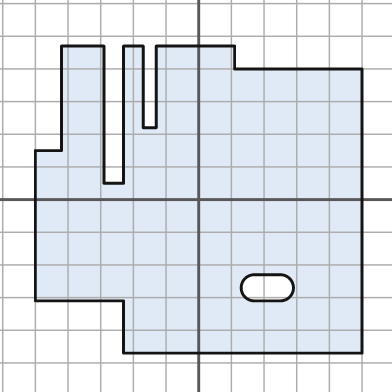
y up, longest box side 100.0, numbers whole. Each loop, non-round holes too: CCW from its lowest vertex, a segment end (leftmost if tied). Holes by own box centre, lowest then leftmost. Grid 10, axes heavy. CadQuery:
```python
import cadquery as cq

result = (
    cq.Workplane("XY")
    .moveTo(-23.0, -47.0)
    .lineTo(50.0, -47.0)
    .lineTo(50.0, 40.0)
    .lineTo(11.0, 40.0)
    .lineTo(11.0, 47.0)
    .lineTo(-13.0, 47.0)
    .lineTo(-13.0, 22.0)
    .lineTo(-17.0, 22.0)
    .lineTo(-17.0, 47.0)
    .lineTo(-23.0, 47.0)
    .lineTo(-23.0, 5.0)
    .lineTo(-29.0, 5.0)
    .lineTo(-29.0, 47.0)
    .lineTo(-42.0, 47.0)
    .lineTo(-42.0, 15.0)
    .lineTo(-50.0, 15.0)
    .lineTo(-50.0, -31.0)
    .lineTo(-23.0, -31.0)
    .close()
    .moveTo(17.0, -31.0)
    .lineTo(25.0, -31.0)
    .threePointArc((29.0, -27.0), (25.0, -23.0))
    .lineTo(17.0, -23.0)
    .threePointArc((13.0, -27.0), (17.0, -31.0))
    .close()
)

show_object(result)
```